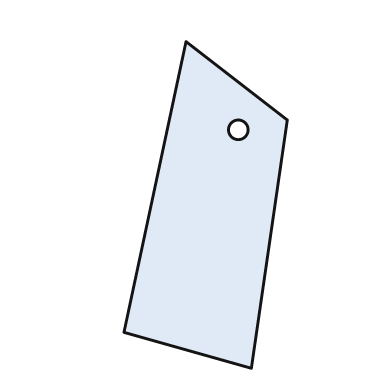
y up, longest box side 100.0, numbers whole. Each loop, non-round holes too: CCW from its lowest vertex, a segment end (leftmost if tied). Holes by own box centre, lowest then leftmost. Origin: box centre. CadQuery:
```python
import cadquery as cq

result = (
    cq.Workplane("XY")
    .moveTo(14.0, -50.0)
    .lineTo(25.0, 26.0)
    .lineTo(-6.0, 50.0)
    .lineTo(-25.0, -39.0)
    .close()
    .moveTo(10.0, 23.0)
    .circle(3.0)
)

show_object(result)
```